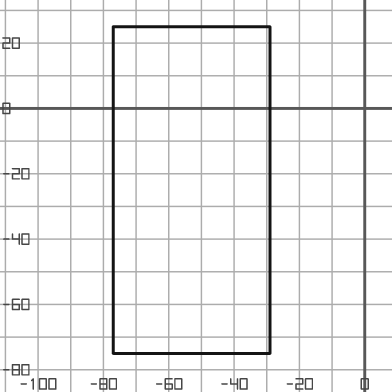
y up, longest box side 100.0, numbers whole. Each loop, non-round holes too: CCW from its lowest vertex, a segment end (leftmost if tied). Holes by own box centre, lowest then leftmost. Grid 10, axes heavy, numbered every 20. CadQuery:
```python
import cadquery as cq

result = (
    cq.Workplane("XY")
    .moveTo(-77.0, -75.0)
    .lineTo(-29.0, -75.0)
    .lineTo(-29.0, 25.0)
    .lineTo(-77.0, 25.0)
    .close()
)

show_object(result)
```